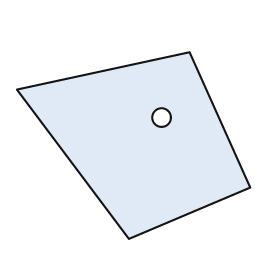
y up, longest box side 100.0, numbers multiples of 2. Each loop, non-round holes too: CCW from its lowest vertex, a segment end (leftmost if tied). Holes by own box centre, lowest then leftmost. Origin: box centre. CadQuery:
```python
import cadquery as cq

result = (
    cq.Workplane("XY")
    .moveTo(-2.0, -40.0)
    .lineTo(50.0, -18.0)
    .lineTo(24.0, 40.0)
    .lineTo(-50.0, 24.0)
    .close()
    .moveTo(12.0, 12.0)
    .circle(4.0)
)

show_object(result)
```